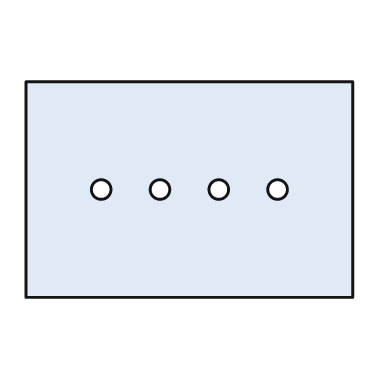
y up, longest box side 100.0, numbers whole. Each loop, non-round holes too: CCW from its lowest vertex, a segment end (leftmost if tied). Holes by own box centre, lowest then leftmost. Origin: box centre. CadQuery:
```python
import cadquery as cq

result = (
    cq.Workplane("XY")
    .moveTo(-50.0, -33.0)
    .lineTo(50.0, -33.0)
    .lineTo(50.0, 33.0)
    .lineTo(-50.0, 33.0)
    .close()
    .moveTo(-27.0, 0.0)
    .circle(3.0)
    .moveTo(-9.0, 0.0)
    .circle(3.0)
    .moveTo(9.0, 0.0)
    .circle(3.0)
    .moveTo(27.0, 0.0)
    .circle(3.0)
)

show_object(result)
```